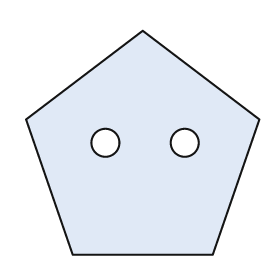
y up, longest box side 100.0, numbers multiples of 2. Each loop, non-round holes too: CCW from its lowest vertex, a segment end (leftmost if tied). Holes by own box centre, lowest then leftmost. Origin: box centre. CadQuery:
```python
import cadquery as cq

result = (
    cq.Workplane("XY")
    .moveTo(-30.0, -48.0)
    .lineTo(30.0, -48.0)
    .lineTo(50.0, 10.0)
    .lineTo(0.0, 48.0)
    .lineTo(-50.0, 10.0)
    .close()
    .moveTo(-16.0, 0.0)
    .circle(6.0)
    .moveTo(18.0, 0.0)
    .circle(6.0)
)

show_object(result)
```